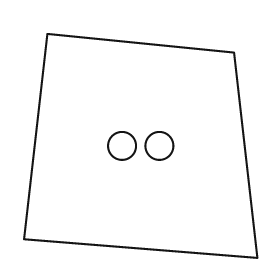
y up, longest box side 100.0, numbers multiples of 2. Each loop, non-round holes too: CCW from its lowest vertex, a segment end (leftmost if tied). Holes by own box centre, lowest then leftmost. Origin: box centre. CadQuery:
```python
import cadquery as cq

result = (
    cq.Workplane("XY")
    .moveTo(50.0, -48.0)
    .lineTo(40.0, 40.0)
    .lineTo(-40.0, 48.0)
    .lineTo(-50.0, -40.0)
    .close()
    .moveTo(-8.0, 0.0)
    .circle(6.0)
    .moveTo(8.0, 0.0)
    .circle(6.0)
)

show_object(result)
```